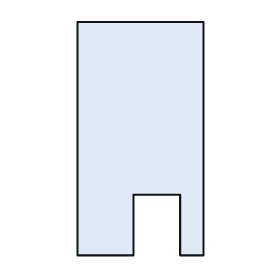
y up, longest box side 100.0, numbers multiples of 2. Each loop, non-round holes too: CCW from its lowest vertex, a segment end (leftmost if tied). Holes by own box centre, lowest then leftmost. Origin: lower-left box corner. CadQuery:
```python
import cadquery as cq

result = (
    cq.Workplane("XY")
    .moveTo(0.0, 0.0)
    .lineTo(24.0, 0.0)
    .lineTo(24.0, 26.0)
    .lineTo(44.0, 26.0)
    .lineTo(44.0, 0.0)
    .lineTo(54.0, 0.0)
    .lineTo(54.0, 100.0)
    .lineTo(0.0, 100.0)
    .close()
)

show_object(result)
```